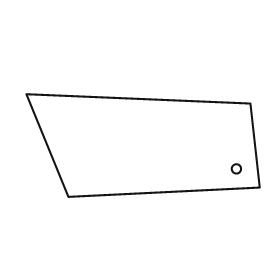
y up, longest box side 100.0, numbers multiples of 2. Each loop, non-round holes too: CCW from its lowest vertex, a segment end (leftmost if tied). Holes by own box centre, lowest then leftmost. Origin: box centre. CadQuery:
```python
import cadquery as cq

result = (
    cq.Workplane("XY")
    .moveTo(-32.0, -22.0)
    .lineTo(50.0, -18.0)
    .lineTo(46.0, 18.0)
    .lineTo(-50.0, 22.0)
    .close()
    .moveTo(40.0, -10.0)
    .circle(2.0)
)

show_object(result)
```